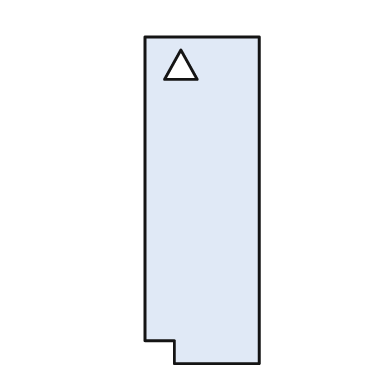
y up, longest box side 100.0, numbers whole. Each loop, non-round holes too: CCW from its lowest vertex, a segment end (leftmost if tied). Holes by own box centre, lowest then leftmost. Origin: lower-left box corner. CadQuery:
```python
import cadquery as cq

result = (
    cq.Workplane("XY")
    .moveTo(9.0, 0.0)
    .lineTo(35.0, 0.0)
    .lineTo(35.0, 100.0)
    .lineTo(0.0, 100.0)
    .lineTo(0.0, 7.0)
    .lineTo(9.0, 7.0)
    .close()
    .moveTo(6.0, 87.0)
    .lineTo(16.0, 87.0)
    .lineTo(11.0, 96.0)
    .close()
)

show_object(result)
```